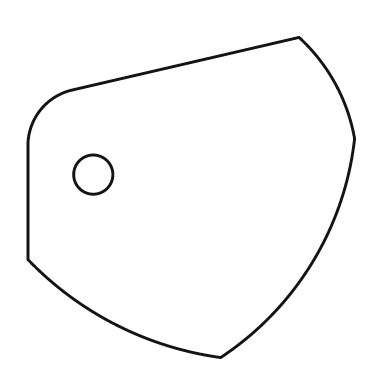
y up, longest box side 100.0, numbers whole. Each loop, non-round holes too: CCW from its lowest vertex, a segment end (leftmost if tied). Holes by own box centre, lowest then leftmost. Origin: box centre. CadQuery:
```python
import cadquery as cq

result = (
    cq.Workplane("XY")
    .moveTo(9.0, -49.0)
    .threePointArc((37.0, -20.0), (50.0, 18.0))
    .threePointArc((44.0, 35.0), (33.0, 49.0))
    .lineTo(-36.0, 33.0)
    .threePointArc((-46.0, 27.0), (-50.0, 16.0))
    .lineTo(-50.0, -19.0)
    .threePointArc((-23.0, -39.0), (9.0, -49.0))
    .close()
    .moveTo(-30.0, 7.0)
    .circle(6.0)
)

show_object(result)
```